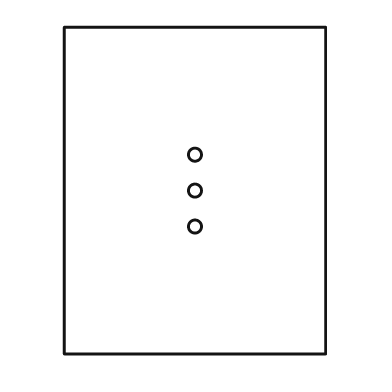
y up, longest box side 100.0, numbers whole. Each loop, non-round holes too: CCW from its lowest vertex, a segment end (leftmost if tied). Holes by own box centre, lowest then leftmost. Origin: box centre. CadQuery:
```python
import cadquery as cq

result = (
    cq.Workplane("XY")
    .moveTo(-40.0, -50.0)
    .lineTo(40.0, -50.0)
    .lineTo(40.0, 50.0)
    .lineTo(-40.0, 50.0)
    .close()
    .moveTo(0.0, -11.0)
    .circle(2.0)
    .moveTo(0.0, 0.0)
    .circle(2.0)
    .moveTo(0.0, 11.0)
    .circle(2.0)
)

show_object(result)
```